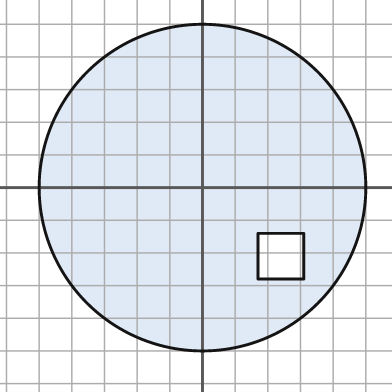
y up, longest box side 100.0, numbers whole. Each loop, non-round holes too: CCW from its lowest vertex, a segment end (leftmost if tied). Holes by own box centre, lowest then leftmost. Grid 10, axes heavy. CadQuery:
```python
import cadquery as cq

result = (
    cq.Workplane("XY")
    .moveTo(0.0, 0.0)
    .circle(50.0)
    .moveTo(17.0, -28.0)
    .lineTo(31.0, -28.0)
    .lineTo(31.0, -14.0)
    .lineTo(17.0, -14.0)
    .close()
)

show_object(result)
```